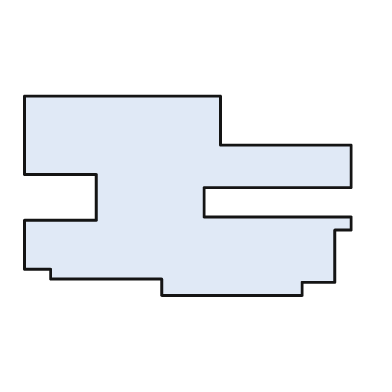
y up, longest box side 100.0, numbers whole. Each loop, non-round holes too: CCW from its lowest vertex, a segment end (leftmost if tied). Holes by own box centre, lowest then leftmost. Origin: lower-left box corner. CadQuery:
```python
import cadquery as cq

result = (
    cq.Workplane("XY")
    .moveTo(42.0, 0.0)
    .lineTo(85.0, 0.0)
    .lineTo(85.0, 4.0)
    .lineTo(95.0, 4.0)
    .lineTo(95.0, 20.0)
    .lineTo(100.0, 20.0)
    .lineTo(100.0, 24.0)
    .lineTo(55.0, 24.0)
    .lineTo(55.0, 33.0)
    .lineTo(100.0, 33.0)
    .lineTo(100.0, 46.0)
    .lineTo(60.0, 46.0)
    .lineTo(60.0, 61.0)
    .lineTo(0.0, 61.0)
    .lineTo(0.0, 37.0)
    .lineTo(22.0, 37.0)
    .lineTo(22.0, 23.0)
    .lineTo(0.0, 23.0)
    .lineTo(0.0, 8.0)
    .lineTo(8.0, 8.0)
    .lineTo(8.0, 5.0)
    .lineTo(42.0, 5.0)
    .close()
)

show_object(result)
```